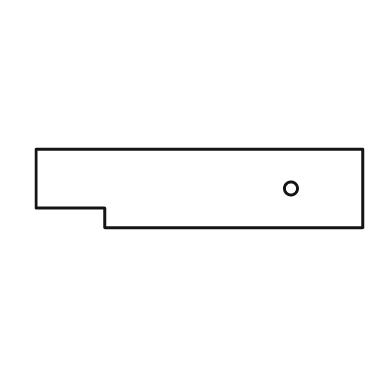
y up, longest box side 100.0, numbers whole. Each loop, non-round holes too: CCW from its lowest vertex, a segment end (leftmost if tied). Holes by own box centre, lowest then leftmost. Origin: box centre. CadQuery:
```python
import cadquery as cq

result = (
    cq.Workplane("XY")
    .moveTo(-29.0, -12.0)
    .lineTo(50.0, -12.0)
    .lineTo(50.0, 12.0)
    .lineTo(-50.0, 12.0)
    .lineTo(-50.0, -6.0)
    .lineTo(-29.0, -6.0)
    .close()
    .moveTo(28.0, 0.0)
    .circle(2.0)
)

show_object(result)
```